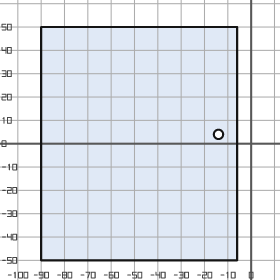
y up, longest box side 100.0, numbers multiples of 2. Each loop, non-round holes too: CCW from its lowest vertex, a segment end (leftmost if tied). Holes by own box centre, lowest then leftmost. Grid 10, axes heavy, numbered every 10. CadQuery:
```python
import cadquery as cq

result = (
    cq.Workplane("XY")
    .moveTo(-90.0, -50.0)
    .lineTo(-6.0, -50.0)
    .lineTo(-6.0, 50.0)
    .lineTo(-90.0, 50.0)
    .close()
    .moveTo(-14.0, 4.0)
    .circle(2.0)
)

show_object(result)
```